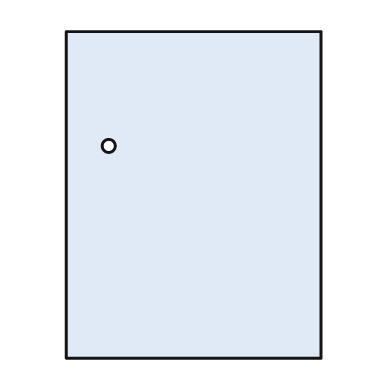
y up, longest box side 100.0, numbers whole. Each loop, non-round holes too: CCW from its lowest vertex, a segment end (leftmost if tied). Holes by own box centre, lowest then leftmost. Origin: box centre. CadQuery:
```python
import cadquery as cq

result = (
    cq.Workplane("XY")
    .moveTo(-39.0, -50.0)
    .lineTo(39.0, -50.0)
    .lineTo(39.0, 50.0)
    .lineTo(-39.0, 50.0)
    .close()
    .moveTo(-26.0, 15.0)
    .circle(2.0)
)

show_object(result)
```